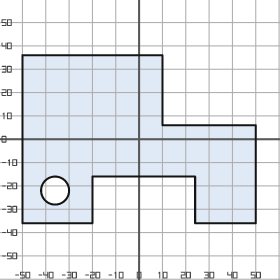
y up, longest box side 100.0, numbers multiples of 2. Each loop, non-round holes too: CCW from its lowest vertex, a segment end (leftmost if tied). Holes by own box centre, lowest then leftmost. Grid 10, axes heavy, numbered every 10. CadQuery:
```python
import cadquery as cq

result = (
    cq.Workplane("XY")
    .moveTo(-50.0, -36.0)
    .lineTo(-20.0, -36.0)
    .lineTo(-20.0, -16.0)
    .lineTo(24.0, -16.0)
    .lineTo(24.0, -36.0)
    .lineTo(50.0, -36.0)
    .lineTo(50.0, 6.0)
    .lineTo(10.0, 6.0)
    .lineTo(10.0, 36.0)
    .lineTo(-50.0, 36.0)
    .close()
    .moveTo(-36.0, -22.0)
    .circle(6.0)
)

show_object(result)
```